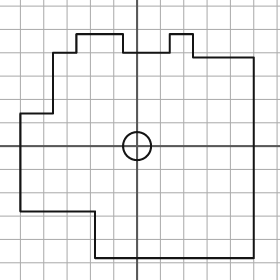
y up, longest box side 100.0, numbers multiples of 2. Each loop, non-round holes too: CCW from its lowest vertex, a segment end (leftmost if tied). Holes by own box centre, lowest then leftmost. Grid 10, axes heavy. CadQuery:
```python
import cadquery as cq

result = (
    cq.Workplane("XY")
    .moveTo(-18.0, -48.0)
    .lineTo(50.0, -48.0)
    .lineTo(50.0, 38.0)
    .lineTo(24.0, 38.0)
    .lineTo(24.0, 48.0)
    .lineTo(14.0, 48.0)
    .lineTo(14.0, 40.0)
    .lineTo(-6.0, 40.0)
    .lineTo(-6.0, 48.0)
    .lineTo(-26.0, 48.0)
    .lineTo(-26.0, 40.0)
    .lineTo(-36.0, 40.0)
    .lineTo(-36.0, 14.0)
    .lineTo(-50.0, 14.0)
    .lineTo(-50.0, -28.0)
    .lineTo(-18.0, -28.0)
    .close()
    .moveTo(0.0, 0.0)
    .circle(6.0)
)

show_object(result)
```